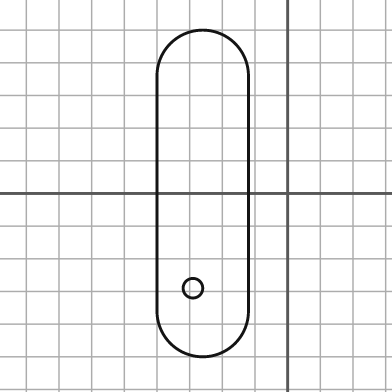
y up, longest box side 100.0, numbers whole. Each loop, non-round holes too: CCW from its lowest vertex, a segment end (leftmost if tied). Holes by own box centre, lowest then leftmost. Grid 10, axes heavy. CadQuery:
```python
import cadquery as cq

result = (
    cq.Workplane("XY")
    .moveTo(-40.0, -36.0)
    .threePointArc((-26.0, -50.0), (-12.0, -36.0))
    .lineTo(-12.0, 36.0)
    .threePointArc((-26.0, 50.0), (-40.0, 36.0))
    .close()
    .moveTo(-29.0, -29.0)
    .circle(3.0)
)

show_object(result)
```